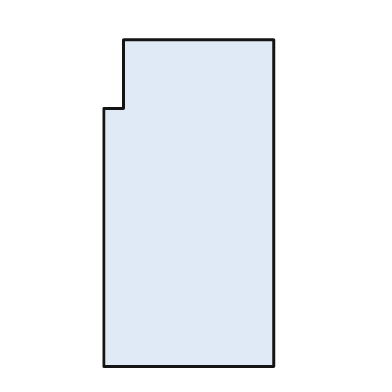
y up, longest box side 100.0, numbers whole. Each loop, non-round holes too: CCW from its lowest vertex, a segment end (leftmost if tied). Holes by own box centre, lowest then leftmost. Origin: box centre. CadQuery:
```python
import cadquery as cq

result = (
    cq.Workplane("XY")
    .moveTo(-26.0, -50.0)
    .lineTo(26.0, -50.0)
    .lineTo(26.0, 50.0)
    .lineTo(-20.0, 50.0)
    .lineTo(-20.0, 29.0)
    .lineTo(-26.0, 29.0)
    .close()
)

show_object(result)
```